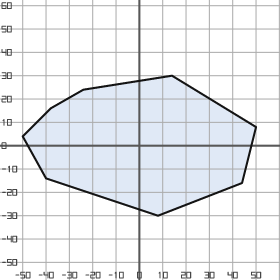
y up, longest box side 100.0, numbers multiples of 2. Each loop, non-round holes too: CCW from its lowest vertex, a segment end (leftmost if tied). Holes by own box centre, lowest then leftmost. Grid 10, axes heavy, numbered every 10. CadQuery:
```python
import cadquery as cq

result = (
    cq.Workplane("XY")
    .moveTo(8.0, -30.0)
    .lineTo(44.0, -16.0)
    .lineTo(50.0, 8.0)
    .lineTo(14.0, 30.0)
    .lineTo(-24.0, 24.0)
    .lineTo(-38.0, 16.0)
    .lineTo(-50.0, 4.0)
    .lineTo(-40.0, -14.0)
    .close()
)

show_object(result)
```